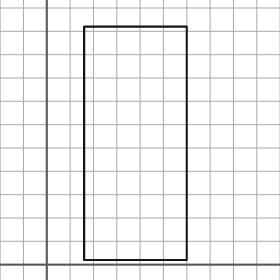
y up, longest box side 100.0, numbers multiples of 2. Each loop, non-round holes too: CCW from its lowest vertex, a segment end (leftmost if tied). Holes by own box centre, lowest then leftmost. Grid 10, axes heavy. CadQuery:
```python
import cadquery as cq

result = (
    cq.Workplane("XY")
    .moveTo(16.0, 2.0)
    .lineTo(60.0, 2.0)
    .lineTo(60.0, 102.0)
    .lineTo(16.0, 102.0)
    .close()
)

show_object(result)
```